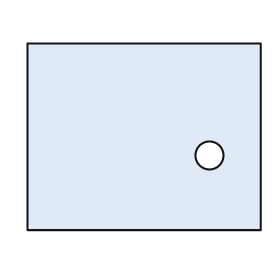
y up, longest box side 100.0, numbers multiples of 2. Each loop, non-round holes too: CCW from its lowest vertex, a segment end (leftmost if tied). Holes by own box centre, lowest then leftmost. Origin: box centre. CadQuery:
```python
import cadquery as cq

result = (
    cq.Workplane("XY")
    .moveTo(-50.0, -40.0)
    .lineTo(50.0, -40.0)
    .lineTo(50.0, 40.0)
    .lineTo(-50.0, 40.0)
    .close()
    .moveTo(28.0, -8.0)
    .circle(6.0)
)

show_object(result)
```